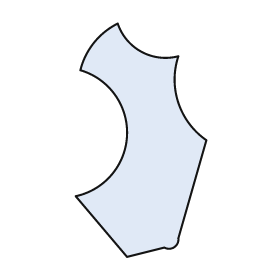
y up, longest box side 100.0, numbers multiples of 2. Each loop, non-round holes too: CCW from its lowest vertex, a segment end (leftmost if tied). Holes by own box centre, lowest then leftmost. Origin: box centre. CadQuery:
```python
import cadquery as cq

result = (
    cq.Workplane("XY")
    .moveTo(-6.0, -50.0)
    .lineTo(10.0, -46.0)
    .threePointArc((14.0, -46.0), (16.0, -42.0))
    .lineTo(28.0, 0.0)
    .threePointArc((16.0, 16.0), (16.0, 36.0))
    .threePointArc((0.0, 38.0), (-10.0, 50.0))
    .threePointArc((-20.0, 42.0), (-26.0, 30.0))
    .threePointArc((-6.0, 2.0), (-28.0, -24.0))
    .close()
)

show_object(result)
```